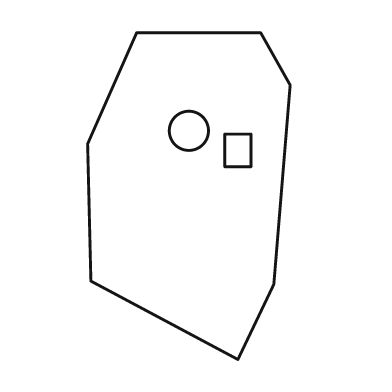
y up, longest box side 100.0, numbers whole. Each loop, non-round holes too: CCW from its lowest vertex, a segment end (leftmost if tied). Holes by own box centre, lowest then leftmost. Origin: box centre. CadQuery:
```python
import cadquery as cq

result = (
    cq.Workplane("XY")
    .moveTo(15.0, -50.0)
    .lineTo(26.0, -27.0)
    .lineTo(31.0, 34.0)
    .lineTo(22.0, 50.0)
    .lineTo(-16.0, 50.0)
    .lineTo(-31.0, 16.0)
    .lineTo(-30.0, -26.0)
    .close()
    .moveTo(11.0, 9.0)
    .lineTo(19.0, 9.0)
    .lineTo(19.0, 19.0)
    .lineTo(11.0, 19.0)
    .close()
    .moveTo(0.0, 20.0)
    .circle(6.0)
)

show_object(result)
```